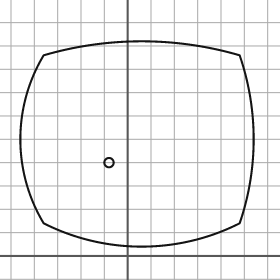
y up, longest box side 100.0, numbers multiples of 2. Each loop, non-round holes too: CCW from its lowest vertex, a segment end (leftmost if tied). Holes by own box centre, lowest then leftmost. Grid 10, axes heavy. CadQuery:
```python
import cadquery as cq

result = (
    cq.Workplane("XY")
    .moveTo(-36.0, 14.0)
    .threePointArc((6.0, 4.0), (48.0, 14.0))
    .threePointArc((54.0, 50.0), (48.0, 86.0))
    .threePointArc((6.0, 92.0), (-36.0, 86.0))
    .threePointArc((-46.0, 50.0), (-36.0, 14.0))
    .close()
    .moveTo(-8.0, 40.0)
    .circle(2.0)
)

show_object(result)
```